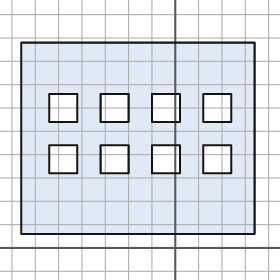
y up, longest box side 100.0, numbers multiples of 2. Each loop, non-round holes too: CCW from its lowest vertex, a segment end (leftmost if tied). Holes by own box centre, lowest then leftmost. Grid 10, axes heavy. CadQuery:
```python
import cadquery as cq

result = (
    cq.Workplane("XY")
    .moveTo(-66.0, 6.0)
    .lineTo(34.0, 6.0)
    .lineTo(34.0, 88.0)
    .lineTo(-66.0, 88.0)
    .close()
    .moveTo(-54.0, 32.0)
    .lineTo(-42.0, 32.0)
    .lineTo(-42.0, 44.0)
    .lineTo(-54.0, 44.0)
    .close()
    .moveTo(-32.0, 32.0)
    .lineTo(-20.0, 32.0)
    .lineTo(-20.0, 44.0)
    .lineTo(-32.0, 44.0)
    .close()
    .moveTo(-10.0, 32.0)
    .lineTo(2.0, 32.0)
    .lineTo(2.0, 44.0)
    .lineTo(-10.0, 44.0)
    .close()
    .moveTo(12.0, 32.0)
    .lineTo(24.0, 32.0)
    .lineTo(24.0, 44.0)
    .lineTo(12.0, 44.0)
    .close()
    .moveTo(-54.0, 54.0)
    .lineTo(-42.0, 54.0)
    .lineTo(-42.0, 66.0)
    .lineTo(-54.0, 66.0)
    .close()
    .moveTo(-32.0, 54.0)
    .lineTo(-20.0, 54.0)
    .lineTo(-20.0, 66.0)
    .lineTo(-32.0, 66.0)
    .close()
    .moveTo(-10.0, 54.0)
    .lineTo(2.0, 54.0)
    .lineTo(2.0, 66.0)
    .lineTo(-10.0, 66.0)
    .close()
    .moveTo(12.0, 54.0)
    .lineTo(24.0, 54.0)
    .lineTo(24.0, 66.0)
    .lineTo(12.0, 66.0)
    .close()
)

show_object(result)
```